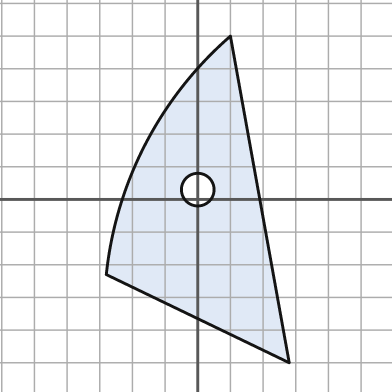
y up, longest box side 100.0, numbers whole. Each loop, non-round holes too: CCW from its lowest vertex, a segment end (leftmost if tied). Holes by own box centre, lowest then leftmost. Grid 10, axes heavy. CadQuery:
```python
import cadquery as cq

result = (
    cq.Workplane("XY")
    .moveTo(28.0, -50.0)
    .lineTo(10.0, 50.0)
    .threePointArc((-16.0, 17.0), (-28.0, -23.0))
    .close()
    .moveTo(0.0, 3.0)
    .circle(5.0)
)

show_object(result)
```